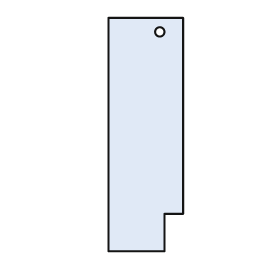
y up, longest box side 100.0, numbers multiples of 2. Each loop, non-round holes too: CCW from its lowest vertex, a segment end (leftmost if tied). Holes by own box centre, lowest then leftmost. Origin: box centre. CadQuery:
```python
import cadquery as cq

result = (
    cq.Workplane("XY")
    .moveTo(-16.0, -50.0)
    .lineTo(8.0, -50.0)
    .lineTo(8.0, -34.0)
    .lineTo(16.0, -34.0)
    .lineTo(16.0, 50.0)
    .lineTo(-16.0, 50.0)
    .close()
    .moveTo(6.0, 44.0)
    .circle(2.0)
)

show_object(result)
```